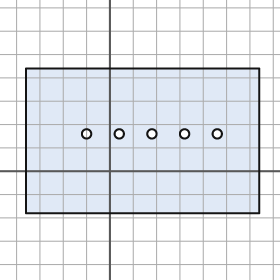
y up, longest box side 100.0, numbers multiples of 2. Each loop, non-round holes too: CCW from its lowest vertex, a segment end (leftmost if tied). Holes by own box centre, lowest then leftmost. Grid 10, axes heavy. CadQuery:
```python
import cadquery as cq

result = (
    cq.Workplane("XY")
    .moveTo(-36.0, -18.0)
    .lineTo(64.0, -18.0)
    .lineTo(64.0, 44.0)
    .lineTo(-36.0, 44.0)
    .close()
    .moveTo(-10.0, 16.0)
    .circle(2.0)
    .moveTo(4.0, 16.0)
    .circle(2.0)
    .moveTo(18.0, 16.0)
    .circle(2.0)
    .moveTo(32.0, 16.0)
    .circle(2.0)
    .moveTo(46.0, 16.0)
    .circle(2.0)
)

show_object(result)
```